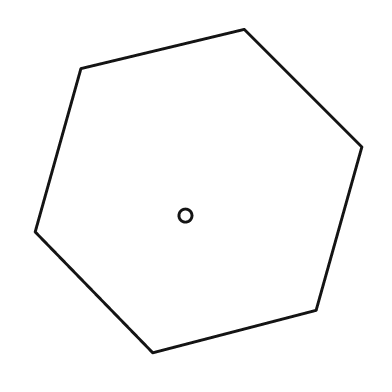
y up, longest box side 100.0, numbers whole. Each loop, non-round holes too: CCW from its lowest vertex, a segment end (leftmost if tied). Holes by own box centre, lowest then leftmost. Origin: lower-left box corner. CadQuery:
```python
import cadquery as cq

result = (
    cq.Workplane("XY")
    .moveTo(36.0, 0.0)
    .lineTo(86.0, 13.0)
    .lineTo(100.0, 63.0)
    .lineTo(64.0, 99.0)
    .lineTo(14.0, 87.0)
    .lineTo(0.0, 37.0)
    .close()
    .moveTo(46.0, 42.0)
    .circle(2.0)
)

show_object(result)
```